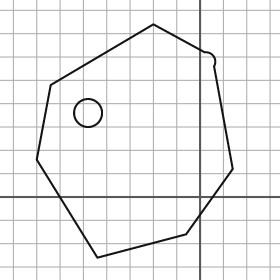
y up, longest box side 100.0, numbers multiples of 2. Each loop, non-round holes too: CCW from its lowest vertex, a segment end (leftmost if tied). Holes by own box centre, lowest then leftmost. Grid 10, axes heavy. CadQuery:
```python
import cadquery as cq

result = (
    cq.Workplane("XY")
    .moveTo(-44.0, -26.0)
    .lineTo(-6.0, -16.0)
    .lineTo(14.0, 12.0)
    .lineTo(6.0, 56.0)
    .threePointArc((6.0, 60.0), (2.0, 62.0))
    .lineTo(-20.0, 74.0)
    .lineTo(-64.0, 48.0)
    .lineTo(-70.0, 16.0)
    .close()
    .moveTo(-48.0, 36.0)
    .circle(6.0)
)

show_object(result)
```